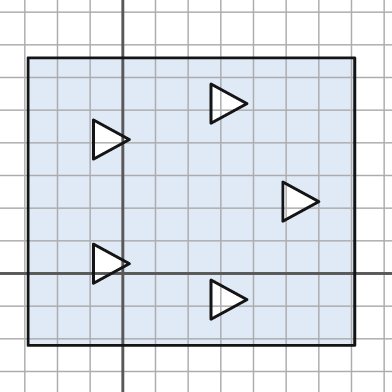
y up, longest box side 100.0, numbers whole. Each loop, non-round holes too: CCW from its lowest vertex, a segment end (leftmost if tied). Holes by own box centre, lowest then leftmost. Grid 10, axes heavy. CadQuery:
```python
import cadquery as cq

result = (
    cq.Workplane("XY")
    .moveTo(-29.0, -22.0)
    .lineTo(71.0, -22.0)
    .lineTo(71.0, 66.0)
    .lineTo(-29.0, 66.0)
    .close()
    .moveTo(27.0, -14.0)
    .lineTo(38.0, -8.0)
    .lineTo(27.0, -2.0)
    .close()
    .moveTo(-9.0, -3.0)
    .lineTo(2.0, 3.0)
    .lineTo(-9.0, 9.0)
    .close()
    .moveTo(49.0, 16.0)
    .lineTo(60.0, 22.0)
    .lineTo(49.0, 28.0)
    .close()
    .moveTo(-9.0, 35.0)
    .lineTo(2.0, 41.0)
    .lineTo(-9.0, 47.0)
    .close()
    .moveTo(27.0, 46.0)
    .lineTo(38.0, 52.0)
    .lineTo(27.0, 58.0)
    .close()
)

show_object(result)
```